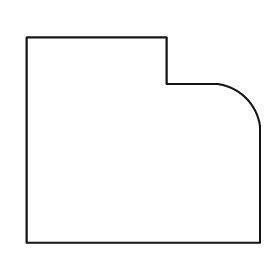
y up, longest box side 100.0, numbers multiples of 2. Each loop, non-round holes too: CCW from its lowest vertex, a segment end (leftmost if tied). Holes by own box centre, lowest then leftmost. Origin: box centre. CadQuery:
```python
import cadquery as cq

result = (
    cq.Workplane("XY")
    .moveTo(-50.0, -44.0)
    .lineTo(50.0, -44.0)
    .lineTo(50.0, 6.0)
    .threePointArc((44.0, 18.0), (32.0, 24.0))
    .lineTo(10.0, 24.0)
    .lineTo(10.0, 44.0)
    .lineTo(-50.0, 44.0)
    .close()
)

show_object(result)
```